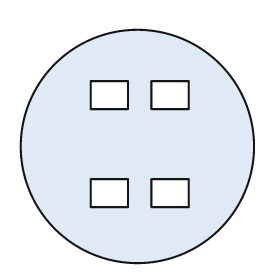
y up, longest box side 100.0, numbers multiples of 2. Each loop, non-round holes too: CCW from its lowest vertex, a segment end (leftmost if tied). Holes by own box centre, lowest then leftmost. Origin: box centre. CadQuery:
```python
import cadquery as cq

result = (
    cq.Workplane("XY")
    .moveTo(0.0, 0.0)
    .circle(50.0)
    .moveTo(-20.0, -26.0)
    .lineTo(-4.0, -26.0)
    .lineTo(-4.0, -14.0)
    .lineTo(-20.0, -14.0)
    .close()
    .moveTo(6.0, -26.0)
    .lineTo(22.0, -26.0)
    .lineTo(22.0, -14.0)
    .lineTo(6.0, -14.0)
    .close()
    .moveTo(-20.0, 16.0)
    .lineTo(-4.0, 16.0)
    .lineTo(-4.0, 28.0)
    .lineTo(-20.0, 28.0)
    .close()
    .moveTo(6.0, 16.0)
    .lineTo(22.0, 16.0)
    .lineTo(22.0, 28.0)
    .lineTo(6.0, 28.0)
    .close()
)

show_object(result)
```